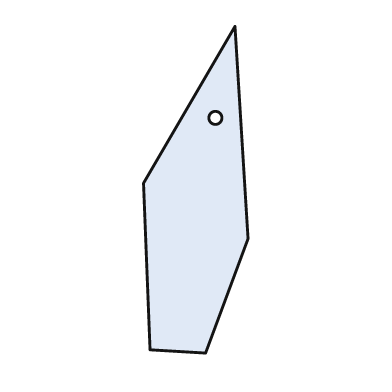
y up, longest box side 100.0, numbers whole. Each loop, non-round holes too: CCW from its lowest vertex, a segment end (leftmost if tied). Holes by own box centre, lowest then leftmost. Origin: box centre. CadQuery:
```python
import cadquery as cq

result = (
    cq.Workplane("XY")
    .moveTo(3.0, -50.0)
    .lineTo(16.0, -15.0)
    .lineTo(12.0, 50.0)
    .lineTo(-16.0, 2.0)
    .lineTo(-14.0, -49.0)
    .close()
    .moveTo(6.0, 22.0)
    .circle(2.0)
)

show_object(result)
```